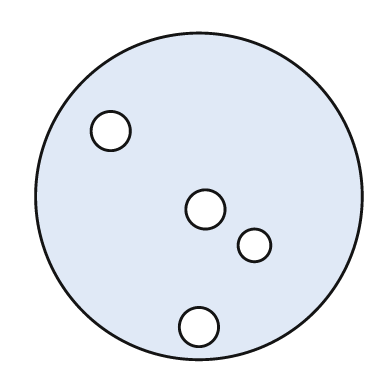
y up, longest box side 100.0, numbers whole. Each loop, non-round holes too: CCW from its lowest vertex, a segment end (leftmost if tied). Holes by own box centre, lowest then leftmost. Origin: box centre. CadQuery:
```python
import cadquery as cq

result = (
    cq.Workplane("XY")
    .moveTo(0.0, 0.0)
    .circle(50.0)
    .moveTo(0.0, -40.0)
    .circle(6.0)
    .moveTo(17.0, -15.0)
    .circle(5.0)
    .moveTo(2.0, -4.0)
    .circle(6.0)
    .moveTo(-27.0, 20.0)
    .circle(6.0)
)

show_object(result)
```